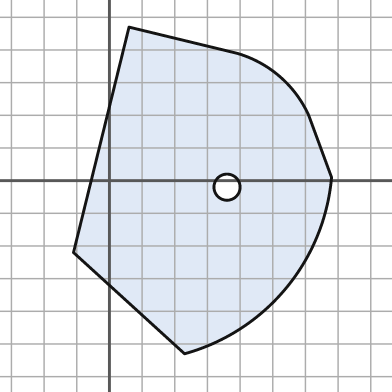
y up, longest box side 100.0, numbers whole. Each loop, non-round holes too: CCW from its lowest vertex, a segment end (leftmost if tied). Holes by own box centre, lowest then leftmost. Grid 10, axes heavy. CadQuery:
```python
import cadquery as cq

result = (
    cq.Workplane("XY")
    .moveTo(23.0, -53.0)
    .threePointArc((54.0, -33.0), (68.0, 1.0))
    .lineTo(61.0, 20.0)
    .threePointArc((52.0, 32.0), (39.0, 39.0))
    .lineTo(6.0, 47.0)
    .lineTo(-11.0, -22.0)
    .close()
    .moveTo(36.0, -2.0)
    .circle(4.0)
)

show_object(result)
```